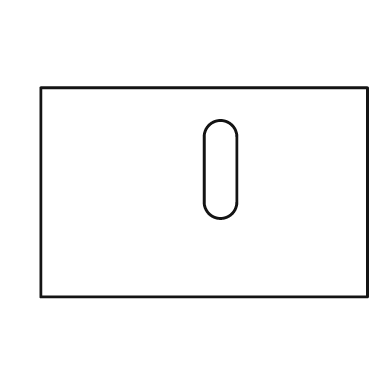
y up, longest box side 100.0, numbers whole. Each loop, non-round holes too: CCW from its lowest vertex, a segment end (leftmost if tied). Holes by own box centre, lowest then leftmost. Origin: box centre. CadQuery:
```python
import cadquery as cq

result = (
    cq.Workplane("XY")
    .moveTo(-50.0, -32.0)
    .lineTo(50.0, -32.0)
    .lineTo(50.0, 32.0)
    .lineTo(-50.0, 32.0)
    .close()
    .moveTo(0.0, -3.0)
    .threePointArc((5.0, -8.0), (10.0, -3.0))
    .lineTo(10.0, 17.0)
    .threePointArc((5.0, 22.0), (0.0, 17.0))
    .close()
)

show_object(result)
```